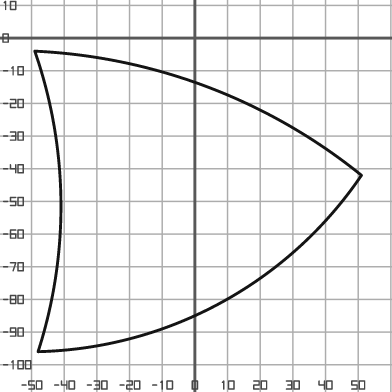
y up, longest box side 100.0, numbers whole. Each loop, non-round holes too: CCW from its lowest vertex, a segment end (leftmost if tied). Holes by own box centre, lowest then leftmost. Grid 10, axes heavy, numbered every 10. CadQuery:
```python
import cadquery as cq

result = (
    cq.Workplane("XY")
    .moveTo(-48.0, -96.0)
    .threePointArc((8.0, -81.0), (51.0, -42.0))
    .threePointArc((4.0, -15.0), (-49.0, -4.0))
    .threePointArc((-41.0, -50.0), (-48.0, -96.0))
    .close()
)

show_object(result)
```